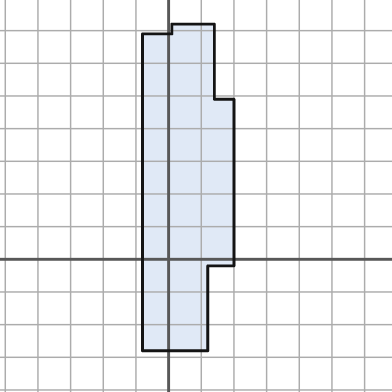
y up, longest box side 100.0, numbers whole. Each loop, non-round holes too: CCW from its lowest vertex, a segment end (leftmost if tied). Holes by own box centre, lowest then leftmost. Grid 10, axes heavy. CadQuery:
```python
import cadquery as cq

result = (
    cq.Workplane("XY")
    .moveTo(-8.0, -28.0)
    .lineTo(12.0, -28.0)
    .lineTo(12.0, -2.0)
    .lineTo(20.0, -2.0)
    .lineTo(20.0, 49.0)
    .lineTo(14.0, 49.0)
    .lineTo(14.0, 72.0)
    .lineTo(1.0, 72.0)
    .lineTo(1.0, 69.0)
    .lineTo(-8.0, 69.0)
    .close()
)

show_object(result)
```